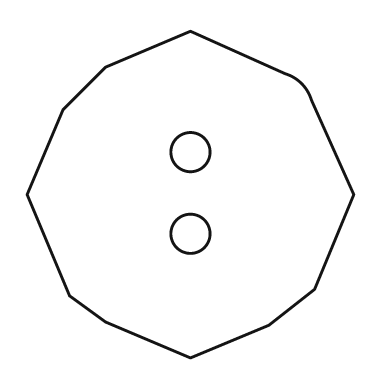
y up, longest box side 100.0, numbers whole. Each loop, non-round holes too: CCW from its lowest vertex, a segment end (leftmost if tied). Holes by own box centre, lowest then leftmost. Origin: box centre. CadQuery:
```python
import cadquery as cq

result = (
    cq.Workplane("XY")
    .moveTo(0.0, -50.0)
    .lineTo(24.0, -40.0)
    .lineTo(38.0, -29.0)
    .lineTo(50.0, 0.0)
    .lineTo(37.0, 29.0)
    .threePointArc((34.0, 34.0), (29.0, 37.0))
    .lineTo(0.0, 50.0)
    .lineTo(-26.0, 39.0)
    .lineTo(-39.0, 26.0)
    .lineTo(-50.0, 0.0)
    .lineTo(-37.0, -31.0)
    .lineTo(-26.0, -39.0)
    .close()
    .moveTo(0.0, -12.0)
    .circle(6.0)
    .moveTo(0.0, 13.0)
    .circle(6.0)
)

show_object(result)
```